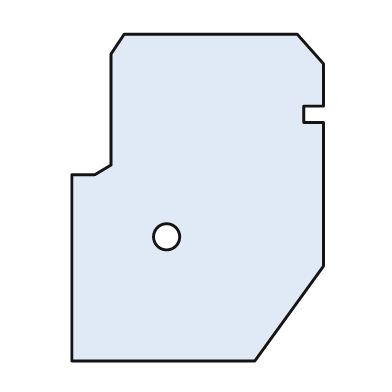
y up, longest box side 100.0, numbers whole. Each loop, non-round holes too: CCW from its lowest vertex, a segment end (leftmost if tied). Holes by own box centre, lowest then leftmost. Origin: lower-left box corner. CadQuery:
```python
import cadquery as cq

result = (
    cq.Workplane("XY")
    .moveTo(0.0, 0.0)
    .lineTo(56.0, 0.0)
    .lineTo(77.0, 29.0)
    .lineTo(77.0, 73.0)
    .lineTo(71.0, 73.0)
    .lineTo(71.0, 78.0)
    .lineTo(77.0, 78.0)
    .lineTo(77.0, 91.0)
    .lineTo(69.0, 100.0)
    .lineTo(16.0, 100.0)
    .lineTo(12.0, 94.0)
    .lineTo(12.0, 60.0)
    .lineTo(7.0, 57.0)
    .lineTo(0.0, 57.0)
    .close()
    .moveTo(29.0, 38.0)
    .circle(4.0)
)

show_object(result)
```